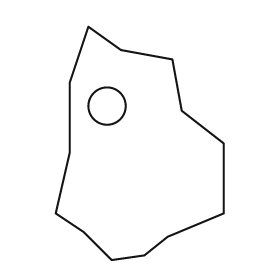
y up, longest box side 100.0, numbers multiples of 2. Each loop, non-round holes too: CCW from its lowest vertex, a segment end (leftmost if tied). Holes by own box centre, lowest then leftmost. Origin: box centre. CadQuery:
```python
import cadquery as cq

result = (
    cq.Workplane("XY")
    .moveTo(-12.0, -50.0)
    .lineTo(2.0, -48.0)
    .lineTo(12.0, -40.0)
    .lineTo(36.0, -30.0)
    .lineTo(36.0, 0.0)
    .lineTo(18.0, 14.0)
    .lineTo(14.0, 36.0)
    .lineTo(-8.0, 40.0)
    .lineTo(-22.0, 50.0)
    .lineTo(-30.0, 26.0)
    .lineTo(-30.0, -4.0)
    .lineTo(-36.0, -30.0)
    .lineTo(-24.0, -38.0)
    .close()
    .moveTo(-14.0, 16.0)
    .circle(8.0)
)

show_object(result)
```